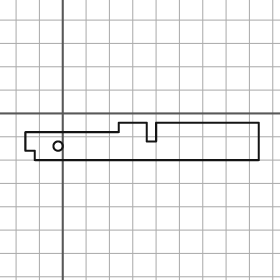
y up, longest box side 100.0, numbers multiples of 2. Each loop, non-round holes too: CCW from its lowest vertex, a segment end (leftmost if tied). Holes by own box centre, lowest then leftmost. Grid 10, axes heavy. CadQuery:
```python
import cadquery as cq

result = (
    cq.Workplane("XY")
    .moveTo(-12.0, -20.0)
    .lineTo(84.0, -20.0)
    .lineTo(84.0, -4.0)
    .lineTo(40.0, -4.0)
    .lineTo(40.0, -12.0)
    .lineTo(36.0, -12.0)
    .lineTo(36.0, -4.0)
    .lineTo(24.0, -4.0)
    .lineTo(24.0, -8.0)
    .lineTo(-16.0, -8.0)
    .lineTo(-16.0, -16.0)
    .lineTo(-12.0, -16.0)
    .close()
    .moveTo(-2.0, -14.0)
    .circle(2.0)
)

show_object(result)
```